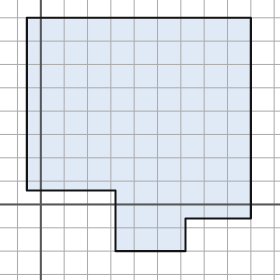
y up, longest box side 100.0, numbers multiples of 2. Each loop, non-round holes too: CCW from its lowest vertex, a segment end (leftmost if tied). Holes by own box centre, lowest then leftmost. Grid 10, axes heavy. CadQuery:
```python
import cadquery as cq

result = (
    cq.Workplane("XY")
    .moveTo(32.0, -20.0)
    .lineTo(62.0, -20.0)
    .lineTo(62.0, -6.0)
    .lineTo(90.0, -6.0)
    .lineTo(90.0, 80.0)
    .lineTo(-6.0, 80.0)
    .lineTo(-6.0, 6.0)
    .lineTo(32.0, 6.0)
    .close()
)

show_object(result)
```